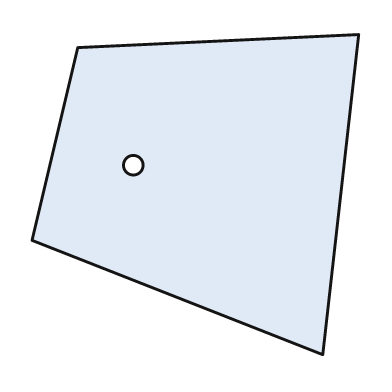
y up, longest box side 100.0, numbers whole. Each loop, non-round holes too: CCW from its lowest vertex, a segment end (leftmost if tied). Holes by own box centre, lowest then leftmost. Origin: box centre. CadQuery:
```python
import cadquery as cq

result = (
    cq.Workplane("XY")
    .moveTo(39.0, -49.0)
    .lineTo(50.0, 49.0)
    .lineTo(-36.0, 45.0)
    .lineTo(-50.0, -14.0)
    .close()
    .moveTo(-19.0, 9.0)
    .circle(3.0)
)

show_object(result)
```